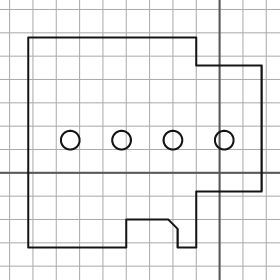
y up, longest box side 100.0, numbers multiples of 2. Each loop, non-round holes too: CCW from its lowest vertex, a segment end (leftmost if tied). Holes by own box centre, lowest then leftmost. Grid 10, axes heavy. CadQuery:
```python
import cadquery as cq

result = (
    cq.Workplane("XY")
    .moveTo(-82.0, -32.0)
    .lineTo(-40.0, -32.0)
    .lineTo(-40.0, -20.0)
    .lineTo(-22.0, -20.0)
    .lineTo(-18.0, -24.0)
    .lineTo(-18.0, -32.0)
    .lineTo(-10.0, -32.0)
    .lineTo(-10.0, -8.0)
    .lineTo(18.0, -8.0)
    .lineTo(18.0, 46.0)
    .lineTo(-10.0, 46.0)
    .lineTo(-10.0, 58.0)
    .lineTo(-82.0, 58.0)
    .close()
    .moveTo(-64.0, 14.0)
    .circle(4.0)
    .moveTo(-42.0, 14.0)
    .circle(4.0)
    .moveTo(-20.0, 14.0)
    .circle(4.0)
    .moveTo(2.0, 14.0)
    .circle(4.0)
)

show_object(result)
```